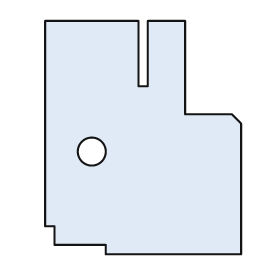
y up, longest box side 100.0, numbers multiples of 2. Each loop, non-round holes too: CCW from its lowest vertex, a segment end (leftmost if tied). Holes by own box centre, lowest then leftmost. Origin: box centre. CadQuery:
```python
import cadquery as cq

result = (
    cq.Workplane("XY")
    .moveTo(-16.0, -50.0)
    .lineTo(42.0, -50.0)
    .lineTo(42.0, 6.0)
    .lineTo(38.0, 10.0)
    .lineTo(18.0, 10.0)
    .lineTo(18.0, 50.0)
    .lineTo(2.0, 50.0)
    .lineTo(2.0, 22.0)
    .lineTo(-2.0, 22.0)
    .lineTo(-2.0, 50.0)
    .lineTo(-42.0, 50.0)
    .lineTo(-42.0, -38.0)
    .lineTo(-38.0, -38.0)
    .lineTo(-38.0, -46.0)
    .lineTo(-16.0, -46.0)
    .close()
    .moveTo(-22.0, -6.0)
    .circle(6.0)
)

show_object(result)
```